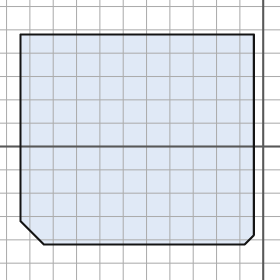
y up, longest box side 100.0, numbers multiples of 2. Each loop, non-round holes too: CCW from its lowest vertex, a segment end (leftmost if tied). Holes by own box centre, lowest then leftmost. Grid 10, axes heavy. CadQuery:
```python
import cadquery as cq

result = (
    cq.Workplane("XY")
    .moveTo(-94.0, -42.0)
    .lineTo(-8.0, -42.0)
    .lineTo(-4.0, -38.0)
    .lineTo(-4.0, 48.0)
    .lineTo(-104.0, 48.0)
    .lineTo(-104.0, -32.0)
    .close()
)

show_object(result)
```